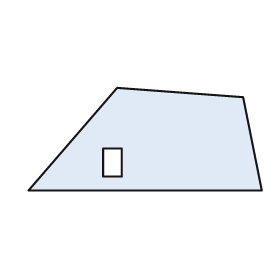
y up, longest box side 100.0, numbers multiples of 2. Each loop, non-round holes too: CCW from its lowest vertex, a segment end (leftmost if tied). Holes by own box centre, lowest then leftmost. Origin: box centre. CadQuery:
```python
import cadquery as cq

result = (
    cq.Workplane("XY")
    .moveTo(-50.0, -22.0)
    .lineTo(50.0, -22.0)
    .lineTo(42.0, 18.0)
    .lineTo(-12.0, 22.0)
    .close()
    .moveTo(-18.0, -16.0)
    .lineTo(-10.0, -16.0)
    .lineTo(-10.0, -4.0)
    .lineTo(-18.0, -4.0)
    .close()
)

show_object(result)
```